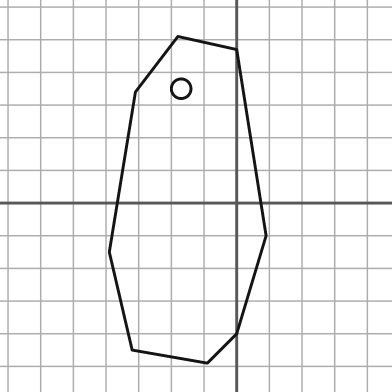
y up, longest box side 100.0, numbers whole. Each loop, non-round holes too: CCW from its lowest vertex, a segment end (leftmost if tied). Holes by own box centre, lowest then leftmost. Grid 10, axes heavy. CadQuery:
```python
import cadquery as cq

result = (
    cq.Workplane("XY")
    .moveTo(-9.0, -49.0)
    .lineTo(0.0, -40.0)
    .lineTo(9.0, -10.0)
    .lineTo(0.0, 47.0)
    .lineTo(-18.0, 51.0)
    .lineTo(-31.0, 34.0)
    .lineTo(-39.0, -15.0)
    .lineTo(-32.0, -45.0)
    .close()
    .moveTo(-17.0, 35.0)
    .circle(3.0)
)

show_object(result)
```